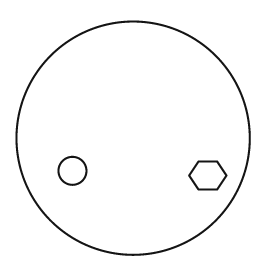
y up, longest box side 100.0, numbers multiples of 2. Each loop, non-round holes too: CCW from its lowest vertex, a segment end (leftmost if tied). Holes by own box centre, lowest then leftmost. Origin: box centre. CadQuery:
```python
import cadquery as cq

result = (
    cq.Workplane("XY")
    .moveTo(0.0, 0.0)
    .circle(50.0)
    .moveTo(28.0, -22.0)
    .lineTo(36.0, -22.0)
    .lineTo(40.0, -16.0)
    .lineTo(36.0, -10.0)
    .lineTo(28.0, -10.0)
    .lineTo(24.0, -16.0)
    .close()
    .moveTo(-26.0, -14.0)
    .circle(6.0)
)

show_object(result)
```